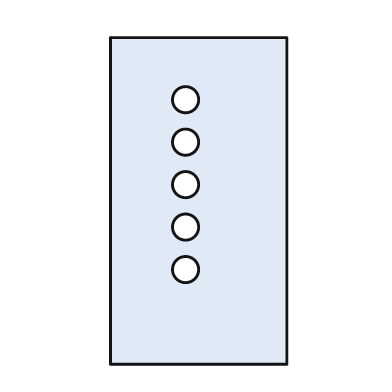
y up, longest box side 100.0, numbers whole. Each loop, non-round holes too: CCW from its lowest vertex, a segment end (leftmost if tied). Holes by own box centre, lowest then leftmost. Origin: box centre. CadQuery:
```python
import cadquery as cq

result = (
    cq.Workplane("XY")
    .moveTo(-27.0, -50.0)
    .lineTo(27.0, -50.0)
    .lineTo(27.0, 50.0)
    .lineTo(-27.0, 50.0)
    .close()
    .moveTo(-4.0, -21.0)
    .circle(4.0)
    .moveTo(-4.0, -8.0)
    .circle(4.0)
    .moveTo(-4.0, 5.0)
    .circle(4.0)
    .moveTo(-4.0, 18.0)
    .circle(4.0)
    .moveTo(-4.0, 31.0)
    .circle(4.0)
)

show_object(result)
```